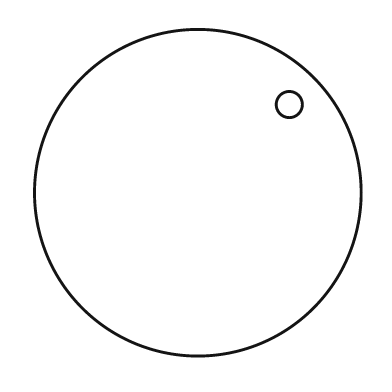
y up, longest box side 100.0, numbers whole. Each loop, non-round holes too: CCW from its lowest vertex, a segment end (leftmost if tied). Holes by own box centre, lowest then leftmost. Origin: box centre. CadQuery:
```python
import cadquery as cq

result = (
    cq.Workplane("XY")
    .moveTo(0.0, 0.0)
    .circle(50.0)
    .moveTo(28.0, 27.0)
    .circle(4.0)
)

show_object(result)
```